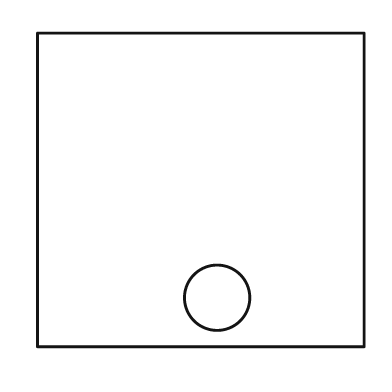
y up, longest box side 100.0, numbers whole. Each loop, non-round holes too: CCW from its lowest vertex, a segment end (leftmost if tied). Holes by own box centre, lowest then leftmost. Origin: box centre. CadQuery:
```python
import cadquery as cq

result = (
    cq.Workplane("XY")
    .moveTo(-50.0, -48.0)
    .lineTo(50.0, -48.0)
    .lineTo(50.0, 48.0)
    .lineTo(-50.0, 48.0)
    .close()
    .moveTo(5.0, -33.0)
    .circle(10.0)
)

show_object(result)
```